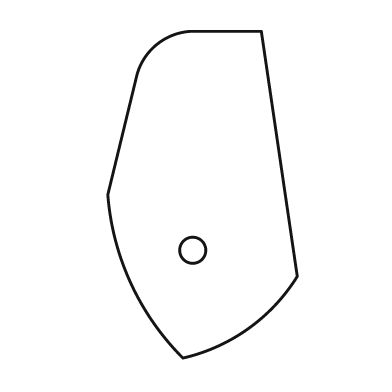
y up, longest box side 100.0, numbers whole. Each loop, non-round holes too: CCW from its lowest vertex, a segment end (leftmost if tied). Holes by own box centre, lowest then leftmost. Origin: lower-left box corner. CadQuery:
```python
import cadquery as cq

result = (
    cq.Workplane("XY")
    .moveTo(23.0, 0.0)
    .threePointArc((43.0, 9.0), (58.0, 25.0))
    .lineTo(47.0, 100.0)
    .lineTo(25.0, 100.0)
    .threePointArc((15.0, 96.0), (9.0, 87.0))
    .lineTo(0.0, 50.0)
    .threePointArc((7.0, 23.0), (23.0, 0.0))
    .close()
    .moveTo(26.0, 33.0)
    .circle(4.0)
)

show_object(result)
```